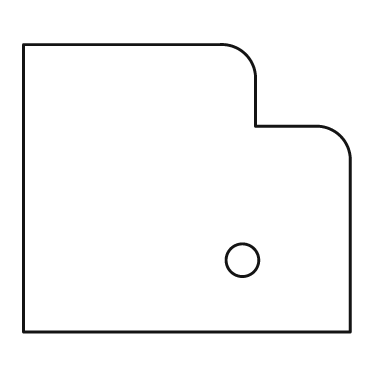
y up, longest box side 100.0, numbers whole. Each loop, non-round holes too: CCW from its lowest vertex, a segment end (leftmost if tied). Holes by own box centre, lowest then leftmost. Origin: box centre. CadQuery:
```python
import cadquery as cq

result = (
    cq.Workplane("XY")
    .moveTo(-50.0, -44.0)
    .lineTo(50.0, -44.0)
    .lineTo(50.0, 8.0)
    .threePointArc((47.0, 16.0), (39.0, 19.0))
    .lineTo(21.0, 19.0)
    .lineTo(21.0, 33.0)
    .threePointArc((18.0, 41.0), (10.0, 44.0))
    .lineTo(-50.0, 44.0)
    .close()
    .moveTo(17.0, -22.0)
    .circle(5.0)
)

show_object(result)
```